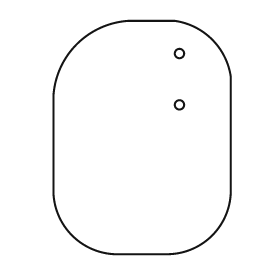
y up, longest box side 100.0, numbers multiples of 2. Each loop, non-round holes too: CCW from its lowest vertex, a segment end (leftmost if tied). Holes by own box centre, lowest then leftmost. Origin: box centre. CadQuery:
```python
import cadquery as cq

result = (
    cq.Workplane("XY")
    .moveTo(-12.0, -50.0)
    .lineTo(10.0, -50.0)
    .threePointArc((30.0, -42.0), (38.0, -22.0))
    .lineTo(38.0, 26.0)
    .threePointArc((30.0, 42.0), (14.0, 50.0))
    .lineTo(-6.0, 50.0)
    .threePointArc((-28.0, 40.0), (-38.0, 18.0))
    .lineTo(-38.0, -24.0)
    .threePointArc((-30.0, -42.0), (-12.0, -50.0))
    .close()
    .moveTo(16.0, 14.0)
    .circle(2.0)
    .moveTo(16.0, 36.0)
    .circle(2.0)
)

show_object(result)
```